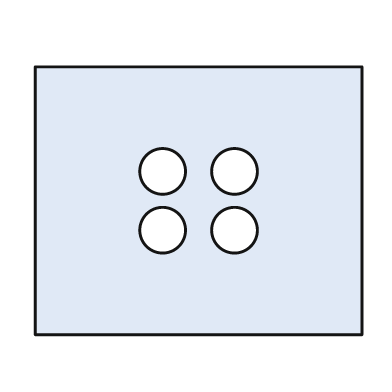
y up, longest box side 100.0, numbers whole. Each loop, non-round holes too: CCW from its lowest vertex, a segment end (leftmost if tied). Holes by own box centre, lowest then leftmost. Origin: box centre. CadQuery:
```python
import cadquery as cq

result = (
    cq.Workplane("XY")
    .moveTo(-50.0, -41.0)
    .lineTo(50.0, -41.0)
    .lineTo(50.0, 41.0)
    .lineTo(-50.0, 41.0)
    .close()
    .moveTo(-11.0, -9.0)
    .circle(7.0)
    .moveTo(11.0, -9.0)
    .circle(7.0)
    .moveTo(-11.0, 9.0)
    .circle(7.0)
    .moveTo(11.0, 9.0)
    .circle(7.0)
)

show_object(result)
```